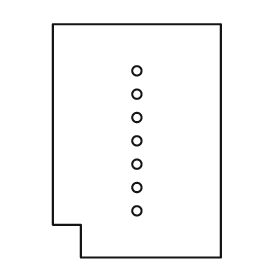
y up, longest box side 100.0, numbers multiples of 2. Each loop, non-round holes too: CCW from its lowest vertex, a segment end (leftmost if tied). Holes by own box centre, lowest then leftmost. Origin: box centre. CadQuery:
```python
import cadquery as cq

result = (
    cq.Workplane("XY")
    .moveTo(-24.0, -50.0)
    .lineTo(36.0, -50.0)
    .lineTo(36.0, 50.0)
    .lineTo(-36.0, 50.0)
    .lineTo(-36.0, -36.0)
    .lineTo(-24.0, -36.0)
    .close()
    .moveTo(0.0, -30.0)
    .circle(2.0)
    .moveTo(0.0, -20.0)
    .circle(2.0)
    .moveTo(0.0, -10.0)
    .circle(2.0)
    .moveTo(0.0, 0.0)
    .circle(2.0)
    .moveTo(0.0, 10.0)
    .circle(2.0)
    .moveTo(0.0, 20.0)
    .circle(2.0)
    .moveTo(0.0, 30.0)
    .circle(2.0)
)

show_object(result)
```